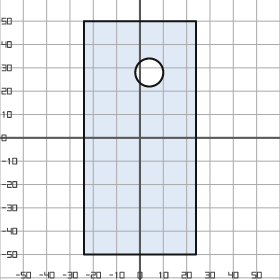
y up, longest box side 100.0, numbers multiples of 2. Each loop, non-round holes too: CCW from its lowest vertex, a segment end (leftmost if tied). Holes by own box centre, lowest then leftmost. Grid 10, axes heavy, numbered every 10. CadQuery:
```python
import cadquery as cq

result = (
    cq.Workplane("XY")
    .moveTo(-24.0, -50.0)
    .lineTo(24.0, -50.0)
    .lineTo(24.0, 50.0)
    .lineTo(-24.0, 50.0)
    .close()
    .moveTo(4.0, 28.0)
    .circle(6.0)
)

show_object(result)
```